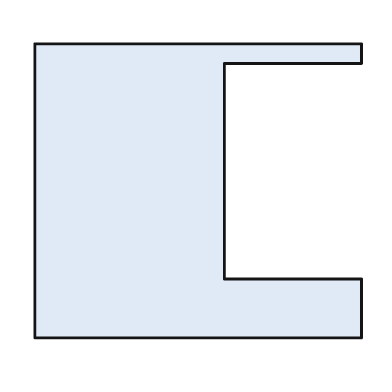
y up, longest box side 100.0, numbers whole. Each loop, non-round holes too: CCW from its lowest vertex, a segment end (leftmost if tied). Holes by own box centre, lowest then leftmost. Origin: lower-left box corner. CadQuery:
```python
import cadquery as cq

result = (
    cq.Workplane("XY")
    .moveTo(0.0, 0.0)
    .lineTo(100.0, 0.0)
    .lineTo(100.0, 18.0)
    .lineTo(58.0, 18.0)
    .lineTo(58.0, 84.0)
    .lineTo(100.0, 84.0)
    .lineTo(100.0, 90.0)
    .lineTo(0.0, 90.0)
    .close()
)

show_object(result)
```